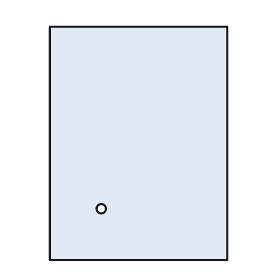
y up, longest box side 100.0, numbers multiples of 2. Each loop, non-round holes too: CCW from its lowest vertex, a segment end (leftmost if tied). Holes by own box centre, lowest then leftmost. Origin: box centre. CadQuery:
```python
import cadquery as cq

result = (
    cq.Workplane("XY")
    .moveTo(-38.0, -50.0)
    .lineTo(38.0, -50.0)
    .lineTo(38.0, 50.0)
    .lineTo(-38.0, 50.0)
    .close()
    .moveTo(-16.0, -28.0)
    .circle(2.0)
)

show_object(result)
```